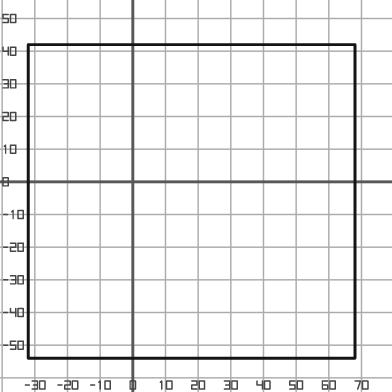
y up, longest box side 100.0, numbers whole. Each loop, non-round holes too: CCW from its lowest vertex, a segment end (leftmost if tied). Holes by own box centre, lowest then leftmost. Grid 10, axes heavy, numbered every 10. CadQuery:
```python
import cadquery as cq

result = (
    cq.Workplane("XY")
    .moveTo(-32.0, -54.0)
    .lineTo(68.0, -54.0)
    .lineTo(68.0, 42.0)
    .lineTo(-32.0, 42.0)
    .close()
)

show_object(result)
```